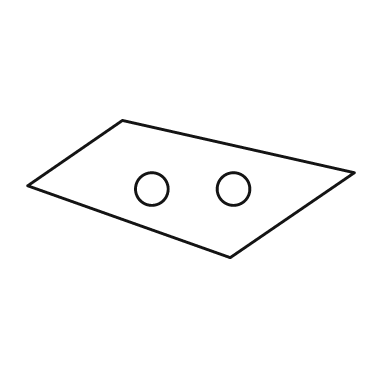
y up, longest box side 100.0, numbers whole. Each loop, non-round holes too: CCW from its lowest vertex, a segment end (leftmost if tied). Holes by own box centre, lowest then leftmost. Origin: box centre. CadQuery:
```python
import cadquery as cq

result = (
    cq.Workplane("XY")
    .moveTo(12.0, -21.0)
    .lineTo(50.0, 5.0)
    .lineTo(-21.0, 21.0)
    .lineTo(-50.0, 1.0)
    .close()
    .moveTo(-12.0, 0.0)
    .circle(5.0)
    .moveTo(13.0, 0.0)
    .circle(5.0)
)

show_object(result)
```